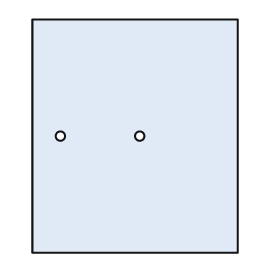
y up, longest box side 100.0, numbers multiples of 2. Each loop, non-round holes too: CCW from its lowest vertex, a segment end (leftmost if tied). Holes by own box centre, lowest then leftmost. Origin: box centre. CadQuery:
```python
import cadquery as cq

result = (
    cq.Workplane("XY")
    .moveTo(-44.0, -50.0)
    .lineTo(44.0, -50.0)
    .lineTo(44.0, 50.0)
    .lineTo(-44.0, 50.0)
    .close()
    .moveTo(-32.0, 0.0)
    .circle(2.0)
    .moveTo(2.0, 0.0)
    .circle(2.0)
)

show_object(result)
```